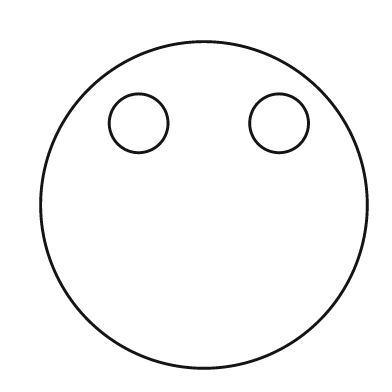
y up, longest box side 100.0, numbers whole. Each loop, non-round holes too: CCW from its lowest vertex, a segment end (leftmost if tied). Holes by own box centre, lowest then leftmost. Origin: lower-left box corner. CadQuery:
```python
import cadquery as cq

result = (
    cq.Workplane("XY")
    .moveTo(50.0, 50.0)
    .circle(50.0)
    .moveTo(30.0, 75.0)
    .circle(9.0)
    .moveTo(73.0, 75.0)
    .circle(9.0)
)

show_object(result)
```